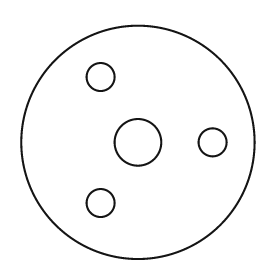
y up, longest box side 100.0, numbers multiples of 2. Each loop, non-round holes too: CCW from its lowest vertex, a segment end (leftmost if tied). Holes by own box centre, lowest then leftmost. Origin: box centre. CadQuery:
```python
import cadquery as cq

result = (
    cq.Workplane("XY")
    .moveTo(0.0, 0.0)
    .circle(50.0)
    .moveTo(-16.0, -26.0)
    .circle(6.0)
    .moveTo(0.0, 0.0)
    .circle(10.0)
    .moveTo(32.0, 0.0)
    .circle(6.0)
    .moveTo(-16.0, 28.0)
    .circle(6.0)
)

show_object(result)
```